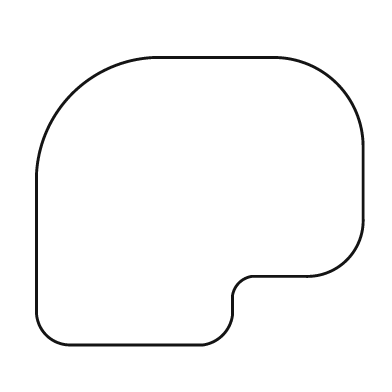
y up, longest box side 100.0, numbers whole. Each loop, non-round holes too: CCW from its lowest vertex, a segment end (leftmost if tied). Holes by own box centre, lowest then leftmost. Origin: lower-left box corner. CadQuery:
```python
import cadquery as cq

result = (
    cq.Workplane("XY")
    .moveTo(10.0, 0.0)
    .lineTo(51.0, 0.0)
    .threePointArc((57.0, 3.0), (60.0, 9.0))
    .lineTo(60.0, 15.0)
    .threePointArc((62.0, 19.0), (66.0, 21.0))
    .lineTo(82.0, 21.0)
    .threePointArc((95.0, 26.0), (100.0, 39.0))
    .lineTo(100.0, 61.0)
    .threePointArc((92.0, 80.0), (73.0, 88.0))
    .lineTo(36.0, 88.0)
    .threePointArc((11.0, 77.0), (0.0, 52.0))
    .lineTo(0.0, 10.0)
    .threePointArc((3.0, 3.0), (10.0, 0.0))
    .close()
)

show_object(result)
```